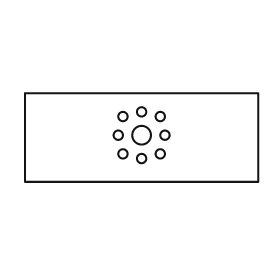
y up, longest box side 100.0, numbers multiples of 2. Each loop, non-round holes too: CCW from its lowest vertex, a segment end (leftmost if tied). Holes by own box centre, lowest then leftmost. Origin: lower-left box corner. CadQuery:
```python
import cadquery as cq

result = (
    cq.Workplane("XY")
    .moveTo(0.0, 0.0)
    .lineTo(100.0, 0.0)
    .lineTo(100.0, 38.0)
    .lineTo(0.0, 38.0)
    .close()
    .moveTo(50.0, 10.0)
    .circle(2.0)
    .moveTo(42.0, 12.0)
    .circle(2.0)
    .moveTo(58.0, 12.0)
    .circle(2.0)
    .moveTo(40.0, 20.0)
    .circle(2.0)
    .moveTo(50.0, 20.0)
    .circle(4.0)
    .moveTo(60.0, 20.0)
    .circle(2.0)
    .moveTo(42.0, 28.0)
    .circle(2.0)
    .moveTo(58.0, 28.0)
    .circle(2.0)
    .moveTo(50.0, 30.0)
    .circle(2.0)
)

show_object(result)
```